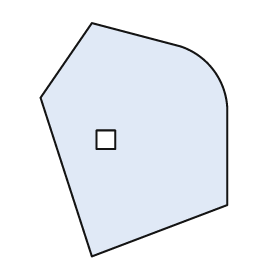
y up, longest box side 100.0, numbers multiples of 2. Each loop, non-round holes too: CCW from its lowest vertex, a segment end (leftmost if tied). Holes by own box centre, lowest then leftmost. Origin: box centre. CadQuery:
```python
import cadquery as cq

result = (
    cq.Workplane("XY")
    .moveTo(-18.0, -50.0)
    .lineTo(40.0, -28.0)
    .lineTo(40.0, 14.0)
    .threePointArc((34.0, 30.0), (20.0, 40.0))
    .lineTo(-18.0, 50.0)
    .lineTo(-40.0, 18.0)
    .close()
    .moveTo(-16.0, -4.0)
    .lineTo(-8.0, -4.0)
    .lineTo(-8.0, 4.0)
    .lineTo(-16.0, 4.0)
    .close()
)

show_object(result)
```